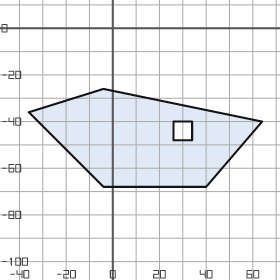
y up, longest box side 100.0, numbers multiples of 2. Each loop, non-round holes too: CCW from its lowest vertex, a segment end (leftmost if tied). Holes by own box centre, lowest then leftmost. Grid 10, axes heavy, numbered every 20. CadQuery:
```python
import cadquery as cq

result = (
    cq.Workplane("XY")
    .moveTo(-4.0, -68.0)
    .lineTo(40.0, -68.0)
    .lineTo(64.0, -40.0)
    .lineTo(-4.0, -26.0)
    .lineTo(-36.0, -36.0)
    .close()
    .moveTo(26.0, -48.0)
    .lineTo(34.0, -48.0)
    .lineTo(34.0, -40.0)
    .lineTo(26.0, -40.0)
    .close()
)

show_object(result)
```